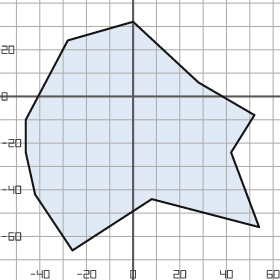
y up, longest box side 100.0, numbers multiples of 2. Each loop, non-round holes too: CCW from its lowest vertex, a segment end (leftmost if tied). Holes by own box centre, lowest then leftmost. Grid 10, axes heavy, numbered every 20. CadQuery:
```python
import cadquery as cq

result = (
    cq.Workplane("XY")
    .moveTo(-26.0, -66.0)
    .lineTo(8.0, -44.0)
    .lineTo(54.0, -56.0)
    .lineTo(42.0, -24.0)
    .lineTo(52.0, -8.0)
    .lineTo(28.0, 6.0)
    .lineTo(0.0, 32.0)
    .lineTo(-28.0, 24.0)
    .lineTo(-46.0, -10.0)
    .lineTo(-46.0, -24.0)
    .lineTo(-42.0, -42.0)
    .close()
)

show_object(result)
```